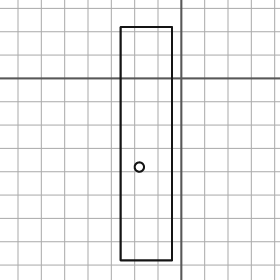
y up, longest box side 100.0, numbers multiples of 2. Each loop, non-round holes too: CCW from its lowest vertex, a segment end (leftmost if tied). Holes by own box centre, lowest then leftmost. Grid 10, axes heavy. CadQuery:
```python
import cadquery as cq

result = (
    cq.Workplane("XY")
    .moveTo(-26.0, -78.0)
    .lineTo(-4.0, -78.0)
    .lineTo(-4.0, 22.0)
    .lineTo(-26.0, 22.0)
    .close()
    .moveTo(-18.0, -38.0)
    .circle(2.0)
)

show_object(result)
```